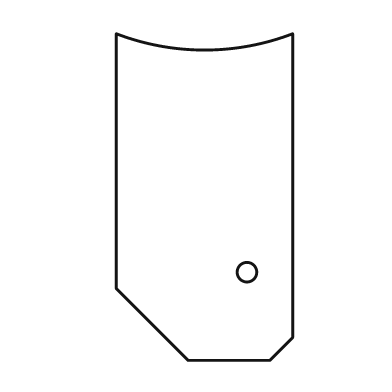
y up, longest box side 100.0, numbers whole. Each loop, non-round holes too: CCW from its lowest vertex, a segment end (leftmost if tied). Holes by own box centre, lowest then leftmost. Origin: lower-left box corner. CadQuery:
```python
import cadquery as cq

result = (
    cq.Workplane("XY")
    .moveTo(22.0, 0.0)
    .lineTo(47.0, 0.0)
    .lineTo(54.0, 7.0)
    .lineTo(54.0, 100.0)
    .threePointArc((27.0, 95.0), (0.0, 100.0))
    .lineTo(0.0, 22.0)
    .close()
    .moveTo(40.0, 27.0)
    .circle(3.0)
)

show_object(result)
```